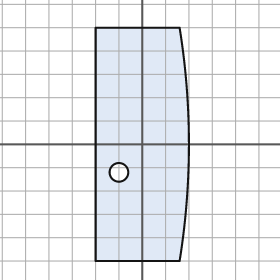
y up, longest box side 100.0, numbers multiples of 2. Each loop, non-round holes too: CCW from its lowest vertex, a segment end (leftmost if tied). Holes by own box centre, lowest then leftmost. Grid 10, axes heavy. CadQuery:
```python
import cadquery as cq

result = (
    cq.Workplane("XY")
    .moveTo(-20.0, -50.0)
    .lineTo(16.0, -50.0)
    .threePointArc((20.0, 0.0), (16.0, 50.0))
    .lineTo(-20.0, 50.0)
    .close()
    .moveTo(-10.0, -12.0)
    .circle(4.0)
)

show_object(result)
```